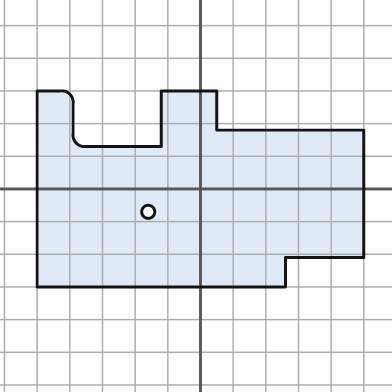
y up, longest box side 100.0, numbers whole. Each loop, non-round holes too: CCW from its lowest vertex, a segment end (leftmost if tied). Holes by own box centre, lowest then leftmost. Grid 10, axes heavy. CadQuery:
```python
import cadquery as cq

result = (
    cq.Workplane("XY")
    .moveTo(-50.0, -30.0)
    .lineTo(26.0, -30.0)
    .lineTo(26.0, -21.0)
    .lineTo(50.0, -21.0)
    .lineTo(50.0, 18.0)
    .lineTo(5.0, 18.0)
    .lineTo(5.0, 30.0)
    .lineTo(-12.0, 30.0)
    .lineTo(-12.0, 13.0)
    .lineTo(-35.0, 13.0)
    .threePointArc((-38.0, 14.0), (-39.0, 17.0))
    .lineTo(-39.0, 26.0)
    .threePointArc((-40.0, 29.0), (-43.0, 30.0))
    .lineTo(-50.0, 30.0)
    .close()
    .moveTo(-16.0, -7.0)
    .circle(2.0)
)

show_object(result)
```